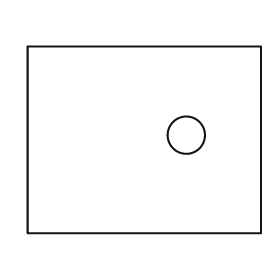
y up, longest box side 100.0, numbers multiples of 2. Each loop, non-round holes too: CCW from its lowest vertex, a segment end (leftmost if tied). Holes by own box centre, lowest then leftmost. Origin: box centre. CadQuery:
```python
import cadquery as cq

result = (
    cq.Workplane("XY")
    .moveTo(-50.0, -40.0)
    .lineTo(50.0, -40.0)
    .lineTo(50.0, 40.0)
    .lineTo(-50.0, 40.0)
    .close()
    .moveTo(18.0, 2.0)
    .circle(8.0)
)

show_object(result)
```